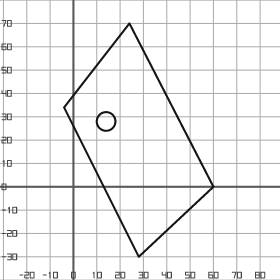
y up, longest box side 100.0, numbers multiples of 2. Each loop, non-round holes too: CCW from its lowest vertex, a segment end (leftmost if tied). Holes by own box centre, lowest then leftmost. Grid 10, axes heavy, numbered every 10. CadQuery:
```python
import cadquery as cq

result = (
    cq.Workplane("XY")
    .moveTo(28.0, -30.0)
    .lineTo(60.0, 0.0)
    .lineTo(24.0, 70.0)
    .lineTo(-4.0, 34.0)
    .close()
    .moveTo(14.0, 28.0)
    .circle(4.0)
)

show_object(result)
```